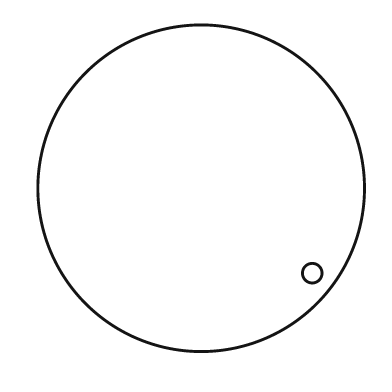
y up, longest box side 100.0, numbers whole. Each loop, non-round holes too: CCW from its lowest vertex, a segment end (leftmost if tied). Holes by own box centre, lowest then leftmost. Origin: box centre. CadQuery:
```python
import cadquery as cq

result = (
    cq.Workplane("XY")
    .moveTo(0.0, 0.0)
    .circle(50.0)
    .moveTo(34.0, -26.0)
    .circle(3.0)
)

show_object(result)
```